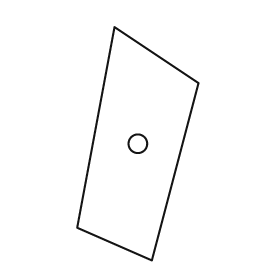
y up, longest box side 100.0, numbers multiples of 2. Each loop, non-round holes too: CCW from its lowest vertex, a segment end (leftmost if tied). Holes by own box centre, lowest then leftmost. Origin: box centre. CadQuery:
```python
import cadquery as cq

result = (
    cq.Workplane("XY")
    .moveTo(6.0, -50.0)
    .lineTo(26.0, 26.0)
    .lineTo(-10.0, 50.0)
    .lineTo(-26.0, -36.0)
    .close()
    .moveTo(0.0, 0.0)
    .circle(4.0)
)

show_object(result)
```